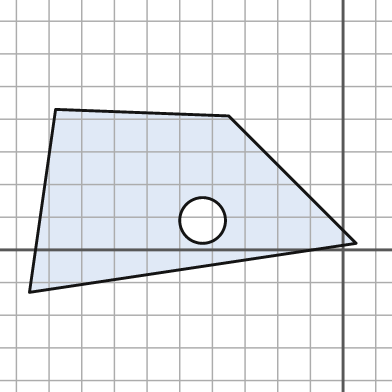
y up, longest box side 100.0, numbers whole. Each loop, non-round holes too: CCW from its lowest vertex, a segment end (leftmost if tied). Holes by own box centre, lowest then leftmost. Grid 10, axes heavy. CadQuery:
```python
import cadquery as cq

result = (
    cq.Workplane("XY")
    .moveTo(-96.0, -13.0)
    .lineTo(4.0, 2.0)
    .lineTo(-35.0, 41.0)
    .lineTo(-88.0, 43.0)
    .close()
    .moveTo(-43.0, 9.0)
    .circle(7.0)
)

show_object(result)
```